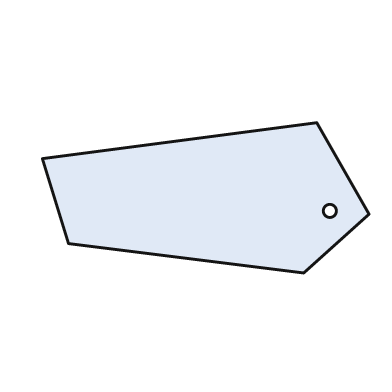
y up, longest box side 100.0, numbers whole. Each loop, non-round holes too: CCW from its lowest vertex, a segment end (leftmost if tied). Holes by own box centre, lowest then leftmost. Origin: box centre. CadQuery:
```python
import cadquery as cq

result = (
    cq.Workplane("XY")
    .moveTo(30.0, -23.0)
    .lineTo(50.0, -5.0)
    .lineTo(34.0, 23.0)
    .lineTo(-50.0, 12.0)
    .lineTo(-42.0, -14.0)
    .close()
    .moveTo(38.0, -4.0)
    .circle(2.0)
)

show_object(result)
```